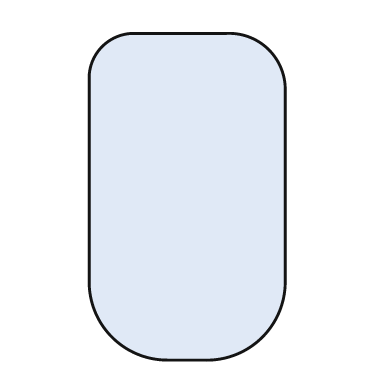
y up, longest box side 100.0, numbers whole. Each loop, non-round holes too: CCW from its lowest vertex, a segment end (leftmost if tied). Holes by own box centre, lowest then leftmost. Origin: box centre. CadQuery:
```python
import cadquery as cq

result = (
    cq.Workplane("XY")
    .moveTo(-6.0, -50.0)
    .lineTo(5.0, -50.0)
    .threePointArc((23.0, -43.0), (30.0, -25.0))
    .lineTo(30.0, 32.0)
    .threePointArc((25.0, 45.0), (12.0, 50.0))
    .lineTo(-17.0, 50.0)
    .threePointArc((-26.0, 46.0), (-30.0, 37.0))
    .lineTo(-30.0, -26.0)
    .threePointArc((-23.0, -43.0), (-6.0, -50.0))
    .close()
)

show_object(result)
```